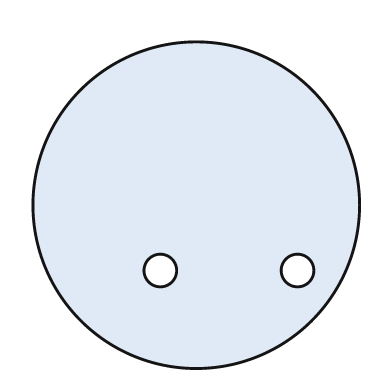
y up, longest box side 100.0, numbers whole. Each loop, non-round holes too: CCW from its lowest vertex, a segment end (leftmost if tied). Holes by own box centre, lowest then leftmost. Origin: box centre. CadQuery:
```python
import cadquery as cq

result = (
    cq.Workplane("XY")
    .moveTo(0.0, 0.0)
    .circle(50.0)
    .moveTo(-11.0, -20.0)
    .circle(5.0)
    .moveTo(31.0, -20.0)
    .circle(5.0)
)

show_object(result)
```